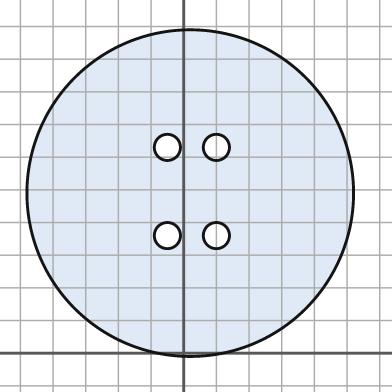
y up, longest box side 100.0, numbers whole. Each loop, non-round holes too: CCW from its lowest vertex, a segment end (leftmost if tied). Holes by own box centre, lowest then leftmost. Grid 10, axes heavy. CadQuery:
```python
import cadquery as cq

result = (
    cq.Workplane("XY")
    .moveTo(2.0, 49.0)
    .circle(50.0)
    .moveTo(-5.0, 36.0)
    .circle(4.0)
    .moveTo(10.0, 36.0)
    .circle(4.0)
    .moveTo(-5.0, 63.0)
    .circle(4.0)
    .moveTo(10.0, 63.0)
    .circle(4.0)
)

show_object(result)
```